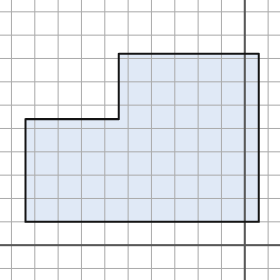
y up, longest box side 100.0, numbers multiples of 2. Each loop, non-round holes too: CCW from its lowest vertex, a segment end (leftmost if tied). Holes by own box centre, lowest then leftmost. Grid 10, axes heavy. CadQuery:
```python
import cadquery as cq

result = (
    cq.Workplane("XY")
    .moveTo(-94.0, 10.0)
    .lineTo(6.0, 10.0)
    .lineTo(6.0, 82.0)
    .lineTo(-54.0, 82.0)
    .lineTo(-54.0, 54.0)
    .lineTo(-94.0, 54.0)
    .close()
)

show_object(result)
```